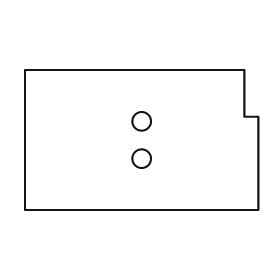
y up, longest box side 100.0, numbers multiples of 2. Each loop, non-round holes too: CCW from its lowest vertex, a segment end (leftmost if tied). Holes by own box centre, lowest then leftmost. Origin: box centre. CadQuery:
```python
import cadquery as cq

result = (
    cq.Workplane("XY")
    .moveTo(-50.0, -30.0)
    .lineTo(50.0, -30.0)
    .lineTo(50.0, 10.0)
    .lineTo(44.0, 10.0)
    .lineTo(44.0, 30.0)
    .lineTo(-50.0, 30.0)
    .close()
    .moveTo(0.0, -8.0)
    .circle(4.0)
    .moveTo(0.0, 8.0)
    .circle(4.0)
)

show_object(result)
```